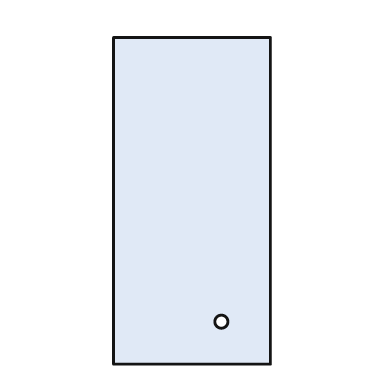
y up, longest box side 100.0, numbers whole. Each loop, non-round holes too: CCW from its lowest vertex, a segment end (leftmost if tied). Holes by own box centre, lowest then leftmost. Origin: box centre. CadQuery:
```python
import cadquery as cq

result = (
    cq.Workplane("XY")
    .moveTo(-24.0, -50.0)
    .lineTo(24.0, -50.0)
    .lineTo(24.0, 50.0)
    .lineTo(-24.0, 50.0)
    .close()
    .moveTo(9.0, -37.0)
    .circle(2.0)
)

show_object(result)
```